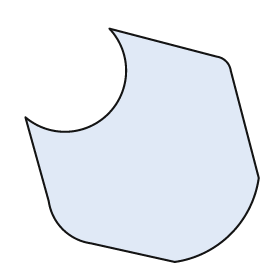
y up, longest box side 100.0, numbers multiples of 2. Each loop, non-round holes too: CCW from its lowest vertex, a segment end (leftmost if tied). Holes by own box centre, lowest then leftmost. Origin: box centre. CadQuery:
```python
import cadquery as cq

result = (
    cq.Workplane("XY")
    .moveTo(14.0, -50.0)
    .threePointArc((38.0, -38.0), (50.0, -14.0))
    .lineTo(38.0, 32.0)
    .threePointArc((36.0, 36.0), (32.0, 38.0))
    .lineTo(-14.0, 50.0)
    .threePointArc((-14.0, 14.0), (-50.0, 12.0))
    .lineTo(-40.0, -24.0)
    .threePointArc((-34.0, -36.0), (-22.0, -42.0))
    .close()
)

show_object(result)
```